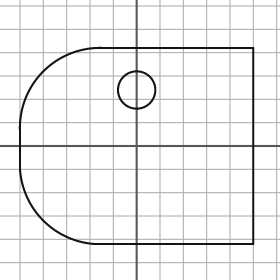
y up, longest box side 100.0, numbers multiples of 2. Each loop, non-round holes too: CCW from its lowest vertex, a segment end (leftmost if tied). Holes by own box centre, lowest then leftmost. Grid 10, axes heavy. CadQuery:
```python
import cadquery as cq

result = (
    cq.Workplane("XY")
    .moveTo(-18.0, -42.0)
    .lineTo(50.0, -42.0)
    .lineTo(50.0, 42.0)
    .lineTo(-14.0, 42.0)
    .threePointArc((-40.0, 32.0), (-50.0, 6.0))
    .lineTo(-50.0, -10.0)
    .threePointArc((-40.0, -32.0), (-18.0, -42.0))
    .close()
    .moveTo(0.0, 24.0)
    .circle(8.0)
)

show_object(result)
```